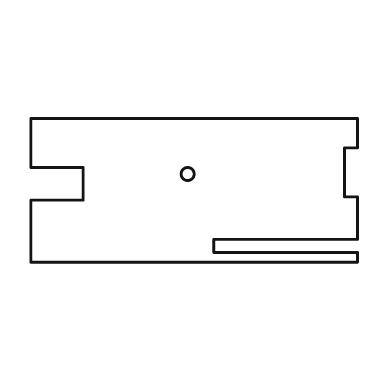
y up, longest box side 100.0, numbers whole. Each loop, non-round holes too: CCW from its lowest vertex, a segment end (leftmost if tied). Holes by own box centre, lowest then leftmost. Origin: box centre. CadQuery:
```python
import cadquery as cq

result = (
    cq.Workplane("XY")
    .moveTo(-50.0, -22.0)
    .lineTo(50.0, -22.0)
    .lineTo(50.0, -19.0)
    .lineTo(6.0, -19.0)
    .lineTo(6.0, -15.0)
    .lineTo(50.0, -15.0)
    .lineTo(50.0, -2.0)
    .lineTo(46.0, -2.0)
    .lineTo(46.0, 13.0)
    .lineTo(50.0, 13.0)
    .lineTo(50.0, 22.0)
    .lineTo(-50.0, 22.0)
    .lineTo(-50.0, 7.0)
    .lineTo(-34.0, 7.0)
    .lineTo(-34.0, -3.0)
    .lineTo(-50.0, -3.0)
    .close()
    .moveTo(-2.0, 5.0)
    .circle(2.0)
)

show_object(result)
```